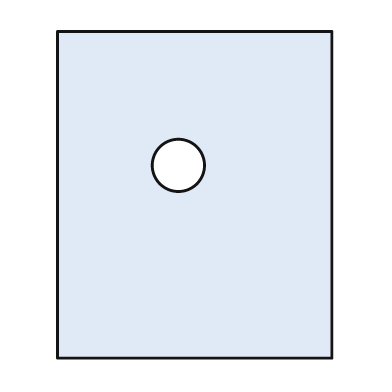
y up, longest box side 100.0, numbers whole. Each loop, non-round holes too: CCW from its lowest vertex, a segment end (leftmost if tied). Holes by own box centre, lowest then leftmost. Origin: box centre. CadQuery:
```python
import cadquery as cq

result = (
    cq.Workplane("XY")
    .moveTo(-42.0, -50.0)
    .lineTo(42.0, -50.0)
    .lineTo(42.0, 50.0)
    .lineTo(-42.0, 50.0)
    .close()
    .moveTo(-5.0, 9.0)
    .circle(8.0)
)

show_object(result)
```